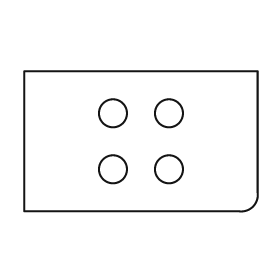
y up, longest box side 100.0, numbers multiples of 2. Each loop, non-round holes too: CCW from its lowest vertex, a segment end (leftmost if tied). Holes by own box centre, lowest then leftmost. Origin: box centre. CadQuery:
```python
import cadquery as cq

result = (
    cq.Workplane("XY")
    .moveTo(-50.0, -30.0)
    .lineTo(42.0, -30.0)
    .threePointArc((48.0, -28.0), (50.0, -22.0))
    .lineTo(50.0, 30.0)
    .lineTo(-50.0, 30.0)
    .close()
    .moveTo(-12.0, -12.0)
    .circle(6.0)
    .moveTo(12.0, -12.0)
    .circle(6.0)
    .moveTo(-12.0, 12.0)
    .circle(6.0)
    .moveTo(12.0, 12.0)
    .circle(6.0)
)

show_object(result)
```